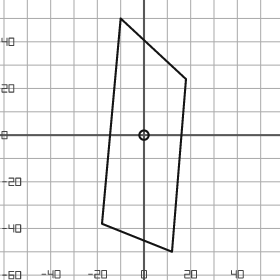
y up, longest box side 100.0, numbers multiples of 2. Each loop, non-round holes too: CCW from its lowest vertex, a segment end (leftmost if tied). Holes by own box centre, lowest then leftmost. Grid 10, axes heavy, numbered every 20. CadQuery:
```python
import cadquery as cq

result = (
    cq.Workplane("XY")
    .moveTo(12.0, -50.0)
    .lineTo(18.0, 24.0)
    .lineTo(-10.0, 50.0)
    .lineTo(-18.0, -38.0)
    .close()
    .moveTo(0.0, 0.0)
    .circle(2.0)
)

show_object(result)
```